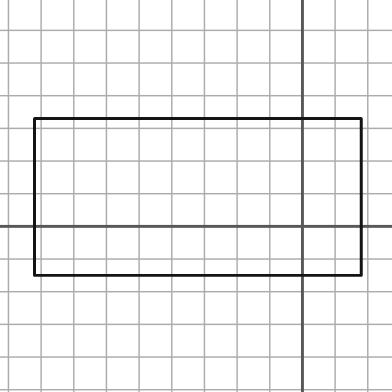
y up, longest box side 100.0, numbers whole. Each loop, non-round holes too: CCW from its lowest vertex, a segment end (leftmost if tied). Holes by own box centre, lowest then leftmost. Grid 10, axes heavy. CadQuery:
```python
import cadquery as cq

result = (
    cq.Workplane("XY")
    .moveTo(-82.0, -15.0)
    .lineTo(18.0, -15.0)
    .lineTo(18.0, 33.0)
    .lineTo(-82.0, 33.0)
    .close()
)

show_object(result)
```